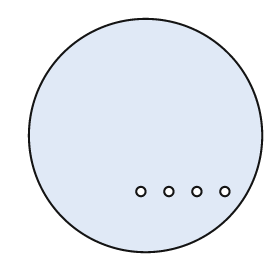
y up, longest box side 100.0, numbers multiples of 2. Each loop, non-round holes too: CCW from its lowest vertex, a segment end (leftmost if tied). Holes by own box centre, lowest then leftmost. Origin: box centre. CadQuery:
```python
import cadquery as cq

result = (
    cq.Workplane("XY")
    .moveTo(0.0, 0.0)
    .circle(50.0)
    .moveTo(-2.0, -24.0)
    .circle(2.0)
    .moveTo(10.0, -24.0)
    .circle(2.0)
    .moveTo(22.0, -24.0)
    .circle(2.0)
    .moveTo(34.0, -24.0)
    .circle(2.0)
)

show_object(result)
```